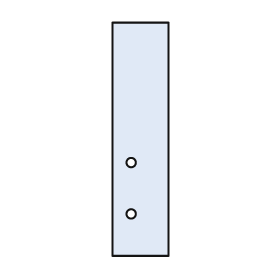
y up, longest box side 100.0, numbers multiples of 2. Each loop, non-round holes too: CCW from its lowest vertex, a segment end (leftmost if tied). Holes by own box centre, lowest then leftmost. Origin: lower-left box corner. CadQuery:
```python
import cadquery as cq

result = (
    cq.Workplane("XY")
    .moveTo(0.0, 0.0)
    .lineTo(24.0, 0.0)
    .lineTo(24.0, 100.0)
    .lineTo(0.0, 100.0)
    .close()
    .moveTo(8.0, 18.0)
    .circle(2.0)
    .moveTo(8.0, 40.0)
    .circle(2.0)
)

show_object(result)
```